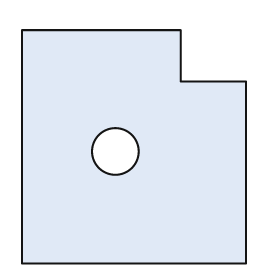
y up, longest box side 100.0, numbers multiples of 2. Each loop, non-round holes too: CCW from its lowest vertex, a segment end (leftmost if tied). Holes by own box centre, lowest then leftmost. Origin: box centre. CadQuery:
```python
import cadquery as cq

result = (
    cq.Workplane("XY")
    .moveTo(-48.0, -50.0)
    .lineTo(48.0, -50.0)
    .lineTo(48.0, 28.0)
    .lineTo(20.0, 28.0)
    .lineTo(20.0, 50.0)
    .lineTo(-48.0, 50.0)
    .close()
    .moveTo(-8.0, -2.0)
    .circle(10.0)
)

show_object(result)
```